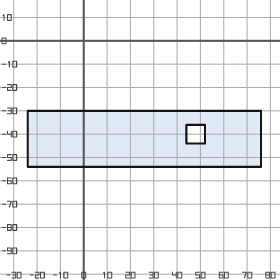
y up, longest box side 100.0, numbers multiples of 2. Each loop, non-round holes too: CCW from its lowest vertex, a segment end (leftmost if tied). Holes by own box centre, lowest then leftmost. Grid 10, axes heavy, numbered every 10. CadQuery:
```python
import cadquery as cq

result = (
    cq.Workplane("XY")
    .moveTo(-24.0, -54.0)
    .lineTo(76.0, -54.0)
    .lineTo(76.0, -30.0)
    .lineTo(-24.0, -30.0)
    .close()
    .moveTo(44.0, -44.0)
    .lineTo(52.0, -44.0)
    .lineTo(52.0, -36.0)
    .lineTo(44.0, -36.0)
    .close()
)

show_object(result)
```